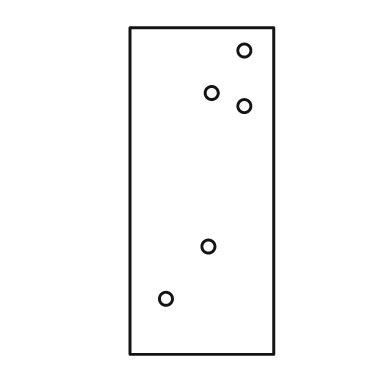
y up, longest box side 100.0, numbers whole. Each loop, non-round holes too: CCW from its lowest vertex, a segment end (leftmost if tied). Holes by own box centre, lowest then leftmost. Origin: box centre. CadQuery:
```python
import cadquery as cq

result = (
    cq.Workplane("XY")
    .moveTo(-22.0, -50.0)
    .lineTo(22.0, -50.0)
    .lineTo(22.0, 50.0)
    .lineTo(-22.0, 50.0)
    .close()
    .moveTo(-11.0, -33.0)
    .circle(2.0)
    .moveTo(2.0, -17.0)
    .circle(2.0)
    .moveTo(13.0, 26.0)
    .circle(2.0)
    .moveTo(3.0, 30.0)
    .circle(2.0)
    .moveTo(13.0, 43.0)
    .circle(2.0)
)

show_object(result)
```